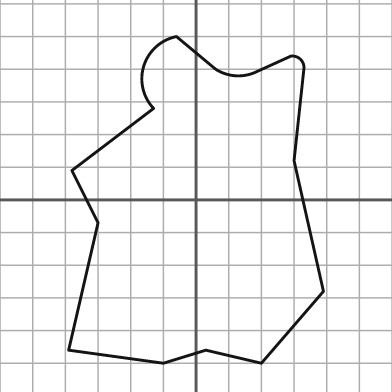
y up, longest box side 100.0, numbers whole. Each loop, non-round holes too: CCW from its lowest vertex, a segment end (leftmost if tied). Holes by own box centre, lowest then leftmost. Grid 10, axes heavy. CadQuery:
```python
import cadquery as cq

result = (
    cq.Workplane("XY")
    .moveTo(-10.0, -50.0)
    .lineTo(3.0, -46.0)
    .lineTo(20.0, -50.0)
    .lineTo(39.0, -28.0)
    .lineTo(30.0, 12.0)
    .lineTo(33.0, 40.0)
    .threePointArc((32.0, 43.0), (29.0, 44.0))
    .lineTo(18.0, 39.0)
    .threePointArc((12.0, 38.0), (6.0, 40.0))
    .lineTo(-6.0, 50.0)
    .threePointArc((-16.0, 41.0), (-13.0, 28.0))
    .lineTo(-38.0, 9.0)
    .lineTo(-30.0, -7.0)
    .lineTo(-39.0, -46.0)
    .close()
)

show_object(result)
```